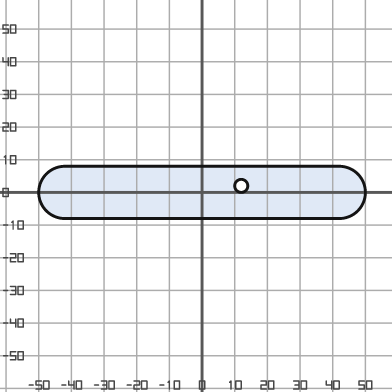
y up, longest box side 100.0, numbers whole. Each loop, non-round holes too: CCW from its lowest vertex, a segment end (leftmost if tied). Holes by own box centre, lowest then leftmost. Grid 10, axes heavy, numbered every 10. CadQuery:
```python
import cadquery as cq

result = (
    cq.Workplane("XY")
    .moveTo(-42.0, -8.0)
    .lineTo(42.0, -8.0)
    .threePointArc((50.0, 0.0), (42.0, 8.0))
    .lineTo(-42.0, 8.0)
    .threePointArc((-50.0, 0.0), (-42.0, -8.0))
    .close()
    .moveTo(12.0, 2.0)
    .circle(2.0)
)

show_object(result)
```